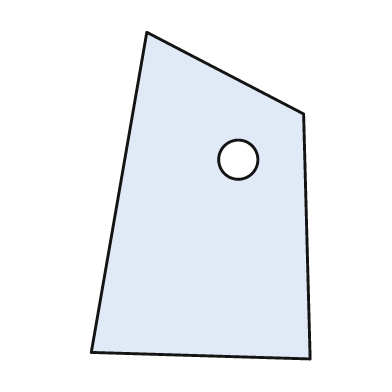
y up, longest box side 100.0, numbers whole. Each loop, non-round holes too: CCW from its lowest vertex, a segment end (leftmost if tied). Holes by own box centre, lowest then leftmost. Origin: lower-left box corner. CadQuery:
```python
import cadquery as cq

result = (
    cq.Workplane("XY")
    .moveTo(67.0, 0.0)
    .lineTo(65.0, 75.0)
    .lineTo(17.0, 100.0)
    .lineTo(0.0, 2.0)
    .close()
    .moveTo(45.0, 61.0)
    .circle(6.0)
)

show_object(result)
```